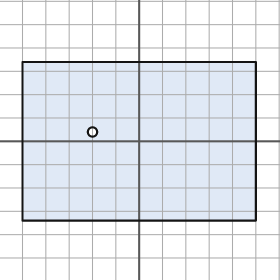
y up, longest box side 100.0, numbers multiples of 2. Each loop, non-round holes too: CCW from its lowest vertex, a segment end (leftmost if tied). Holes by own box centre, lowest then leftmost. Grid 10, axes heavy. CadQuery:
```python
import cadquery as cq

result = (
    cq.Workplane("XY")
    .moveTo(-50.0, -34.0)
    .lineTo(50.0, -34.0)
    .lineTo(50.0, 34.0)
    .lineTo(-50.0, 34.0)
    .close()
    .moveTo(-20.0, 4.0)
    .circle(2.0)
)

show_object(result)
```